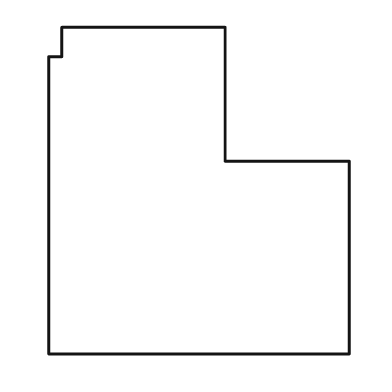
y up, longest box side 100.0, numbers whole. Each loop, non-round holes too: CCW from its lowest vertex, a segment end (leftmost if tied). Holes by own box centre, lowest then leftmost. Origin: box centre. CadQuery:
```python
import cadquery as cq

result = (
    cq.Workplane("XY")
    .moveTo(-46.0, -50.0)
    .lineTo(46.0, -50.0)
    .lineTo(46.0, 9.0)
    .lineTo(8.0, 9.0)
    .lineTo(8.0, 50.0)
    .lineTo(-42.0, 50.0)
    .lineTo(-42.0, 41.0)
    .lineTo(-46.0, 41.0)
    .close()
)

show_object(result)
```